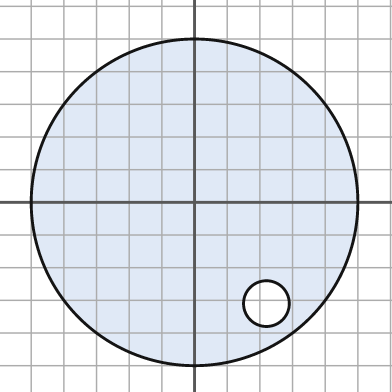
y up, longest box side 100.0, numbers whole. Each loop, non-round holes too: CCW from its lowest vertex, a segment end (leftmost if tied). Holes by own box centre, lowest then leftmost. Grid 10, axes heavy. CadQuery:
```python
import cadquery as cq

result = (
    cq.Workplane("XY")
    .moveTo(0.0, 0.0)
    .circle(50.0)
    .moveTo(22.0, -31.0)
    .circle(7.0)
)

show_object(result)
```